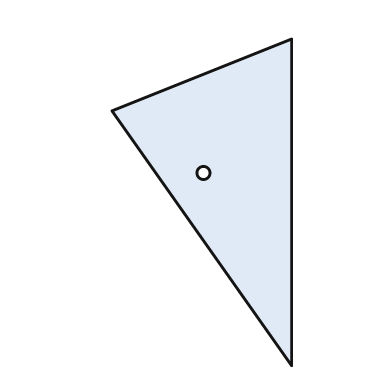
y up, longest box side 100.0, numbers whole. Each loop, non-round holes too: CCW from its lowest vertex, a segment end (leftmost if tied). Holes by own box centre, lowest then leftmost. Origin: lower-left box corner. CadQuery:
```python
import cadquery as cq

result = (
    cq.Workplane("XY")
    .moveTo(55.0, 0.0)
    .lineTo(55.0, 100.0)
    .lineTo(0.0, 78.0)
    .close()
    .moveTo(28.0, 59.0)
    .circle(2.0)
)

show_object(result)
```